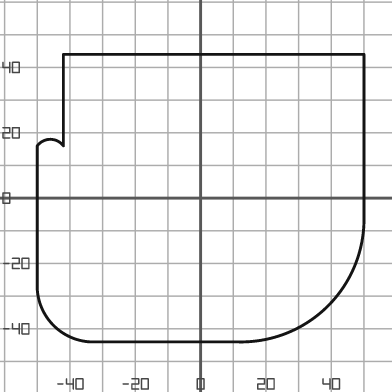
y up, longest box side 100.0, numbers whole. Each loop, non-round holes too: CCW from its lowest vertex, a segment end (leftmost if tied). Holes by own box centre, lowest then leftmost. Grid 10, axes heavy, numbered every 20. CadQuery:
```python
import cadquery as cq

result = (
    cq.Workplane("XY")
    .moveTo(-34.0, -44.0)
    .lineTo(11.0, -44.0)
    .threePointArc((39.0, -33.0), (50.0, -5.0))
    .lineTo(50.0, 44.0)
    .lineTo(-42.0, 44.0)
    .lineTo(-42.0, 16.0)
    .threePointArc((-46.0, 18.0), (-50.0, 16.0))
    .lineTo(-50.0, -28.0)
    .threePointArc((-45.0, -39.0), (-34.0, -44.0))
    .close()
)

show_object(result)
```